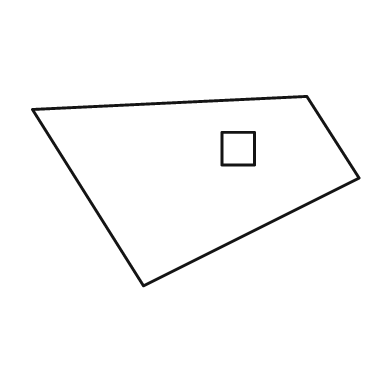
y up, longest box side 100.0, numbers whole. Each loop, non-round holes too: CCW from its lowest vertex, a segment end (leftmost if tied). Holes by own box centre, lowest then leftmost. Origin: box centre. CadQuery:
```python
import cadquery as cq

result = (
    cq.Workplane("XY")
    .moveTo(-16.0, -29.0)
    .lineTo(50.0, 4.0)
    .lineTo(34.0, 29.0)
    .lineTo(-50.0, 25.0)
    .close()
    .moveTo(8.0, 8.0)
    .lineTo(18.0, 8.0)
    .lineTo(18.0, 18.0)
    .lineTo(8.0, 18.0)
    .close()
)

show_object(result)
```